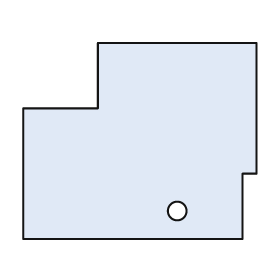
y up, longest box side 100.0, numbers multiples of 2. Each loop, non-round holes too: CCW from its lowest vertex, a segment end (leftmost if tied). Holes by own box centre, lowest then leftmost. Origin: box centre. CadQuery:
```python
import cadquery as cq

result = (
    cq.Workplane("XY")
    .moveTo(-50.0, -42.0)
    .lineTo(44.0, -42.0)
    .lineTo(44.0, -14.0)
    .lineTo(50.0, -14.0)
    .lineTo(50.0, 42.0)
    .lineTo(-18.0, 42.0)
    .lineTo(-18.0, 14.0)
    .lineTo(-50.0, 14.0)
    .close()
    .moveTo(16.0, -30.0)
    .circle(4.0)
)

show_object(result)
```